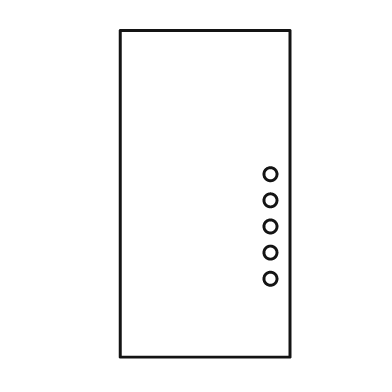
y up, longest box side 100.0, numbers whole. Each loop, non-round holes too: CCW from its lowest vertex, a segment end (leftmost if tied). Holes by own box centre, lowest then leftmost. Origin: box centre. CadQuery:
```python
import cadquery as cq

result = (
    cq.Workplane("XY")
    .moveTo(-26.0, -50.0)
    .lineTo(26.0, -50.0)
    .lineTo(26.0, 50.0)
    .lineTo(-26.0, 50.0)
    .close()
    .moveTo(20.0, -26.0)
    .circle(2.0)
    .moveTo(20.0, -18.0)
    .circle(2.0)
    .moveTo(20.0, -10.0)
    .circle(2.0)
    .moveTo(20.0, -2.0)
    .circle(2.0)
    .moveTo(20.0, 6.0)
    .circle(2.0)
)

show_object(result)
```